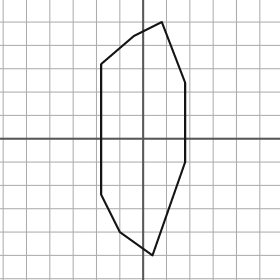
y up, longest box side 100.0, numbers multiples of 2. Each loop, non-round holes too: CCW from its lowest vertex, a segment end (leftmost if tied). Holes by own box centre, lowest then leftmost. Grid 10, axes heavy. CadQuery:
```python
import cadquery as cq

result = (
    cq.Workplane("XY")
    .moveTo(4.0, -50.0)
    .lineTo(18.0, -10.0)
    .lineTo(18.0, 24.0)
    .lineTo(8.0, 50.0)
    .lineTo(-4.0, 44.0)
    .lineTo(-18.0, 32.0)
    .lineTo(-18.0, -24.0)
    .lineTo(-10.0, -40.0)
    .close()
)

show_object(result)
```